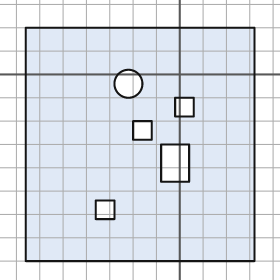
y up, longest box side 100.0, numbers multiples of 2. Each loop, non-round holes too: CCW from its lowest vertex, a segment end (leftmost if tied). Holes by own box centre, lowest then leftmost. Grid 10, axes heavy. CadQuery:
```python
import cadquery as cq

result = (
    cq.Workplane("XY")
    .moveTo(-66.0, -80.0)
    .lineTo(32.0, -80.0)
    .lineTo(32.0, 20.0)
    .lineTo(-66.0, 20.0)
    .close()
    .moveTo(-36.0, -62.0)
    .lineTo(-28.0, -62.0)
    .lineTo(-28.0, -54.0)
    .lineTo(-36.0, -54.0)
    .close()
    .moveTo(-8.0, -46.0)
    .lineTo(4.0, -46.0)
    .lineTo(4.0, -30.0)
    .lineTo(-8.0, -30.0)
    .close()
    .moveTo(-20.0, -28.0)
    .lineTo(-12.0, -28.0)
    .lineTo(-12.0, -20.0)
    .lineTo(-20.0, -20.0)
    .close()
    .moveTo(-2.0, -18.0)
    .lineTo(6.0, -18.0)
    .lineTo(6.0, -10.0)
    .lineTo(-2.0, -10.0)
    .close()
    .moveTo(-22.0, -4.0)
    .circle(6.0)
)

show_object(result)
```